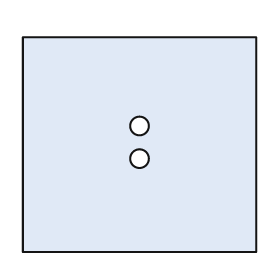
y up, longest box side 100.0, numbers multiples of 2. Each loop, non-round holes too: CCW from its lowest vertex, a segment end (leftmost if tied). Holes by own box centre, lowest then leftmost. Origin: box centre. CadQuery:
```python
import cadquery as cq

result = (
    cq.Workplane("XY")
    .moveTo(-50.0, -46.0)
    .lineTo(50.0, -46.0)
    .lineTo(50.0, 46.0)
    .lineTo(-50.0, 46.0)
    .close()
    .moveTo(0.0, -6.0)
    .circle(4.0)
    .moveTo(0.0, 8.0)
    .circle(4.0)
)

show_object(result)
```